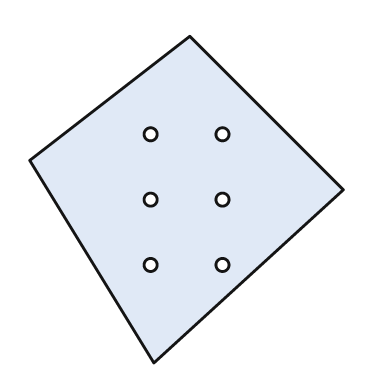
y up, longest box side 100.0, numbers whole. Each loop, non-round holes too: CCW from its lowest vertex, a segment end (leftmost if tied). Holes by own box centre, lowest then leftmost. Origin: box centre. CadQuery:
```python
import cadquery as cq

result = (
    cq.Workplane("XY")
    .moveTo(-10.0, -50.0)
    .lineTo(48.0, 3.0)
    .lineTo(1.0, 50.0)
    .lineTo(-48.0, 12.0)
    .close()
    .moveTo(-11.0, -20.0)
    .circle(2.0)
    .moveTo(11.0, -20.0)
    .circle(2.0)
    .moveTo(-11.0, 0.0)
    .circle(2.0)
    .moveTo(11.0, 0.0)
    .circle(2.0)
    .moveTo(-11.0, 20.0)
    .circle(2.0)
    .moveTo(11.0, 20.0)
    .circle(2.0)
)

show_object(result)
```